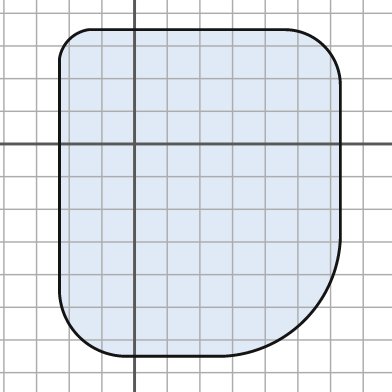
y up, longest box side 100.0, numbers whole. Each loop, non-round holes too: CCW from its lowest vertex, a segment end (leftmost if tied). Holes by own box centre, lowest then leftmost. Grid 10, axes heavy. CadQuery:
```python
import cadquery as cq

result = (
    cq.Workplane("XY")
    .moveTo(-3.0, -65.0)
    .lineTo(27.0, -65.0)
    .threePointArc((52.0, -54.0), (63.0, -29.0))
    .lineTo(63.0, 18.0)
    .threePointArc((58.0, 30.0), (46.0, 35.0))
    .lineTo(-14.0, 35.0)
    .threePointArc((-20.0, 32.0), (-23.0, 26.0))
    .lineTo(-23.0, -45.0)
    .threePointArc((-17.0, -59.0), (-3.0, -65.0))
    .close()
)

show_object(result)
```